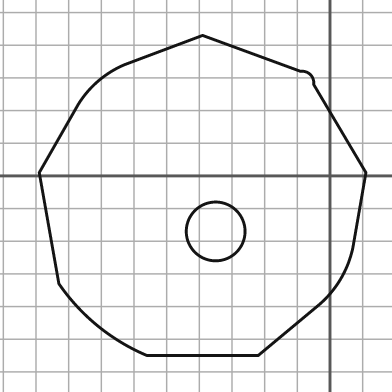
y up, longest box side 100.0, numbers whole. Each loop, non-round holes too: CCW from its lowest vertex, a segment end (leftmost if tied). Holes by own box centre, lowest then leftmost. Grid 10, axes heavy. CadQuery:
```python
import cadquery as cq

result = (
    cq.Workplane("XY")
    .moveTo(-56.0, -55.0)
    .lineTo(-22.0, -55.0)
    .lineTo(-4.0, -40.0)
    .threePointArc((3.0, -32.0), (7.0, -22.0))
    .lineTo(11.0, 1.0)
    .lineTo(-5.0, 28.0)
    .threePointArc((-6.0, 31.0), (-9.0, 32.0))
    .lineTo(-39.0, 43.0)
    .lineTo(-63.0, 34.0)
    .threePointArc((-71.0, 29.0), (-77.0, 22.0))
    .lineTo(-89.0, 1.0)
    .lineTo(-83.0, -33.0)
    .threePointArc((-71.0, -46.0), (-56.0, -55.0))
    .close()
    .moveTo(-35.0, -17.0)
    .circle(9.0)
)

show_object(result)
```